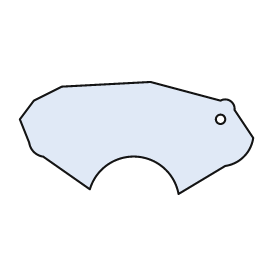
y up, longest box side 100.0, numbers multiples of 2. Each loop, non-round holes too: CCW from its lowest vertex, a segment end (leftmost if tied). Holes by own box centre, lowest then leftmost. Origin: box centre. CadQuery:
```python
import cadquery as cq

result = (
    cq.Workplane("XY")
    .moveTo(18.0, -24.0)
    .lineTo(38.0, -12.0)
    .threePointArc((46.0, -8.0), (50.0, 0.0))
    .lineTo(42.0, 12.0)
    .threePointArc((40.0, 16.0), (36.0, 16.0))
    .lineTo(6.0, 24.0)
    .lineTo(-32.0, 22.0)
    .lineTo(-44.0, 16.0)
    .lineTo(-50.0, 8.0)
    .lineTo(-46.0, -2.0)
    .threePointArc((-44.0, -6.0), (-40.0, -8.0))
    .lineTo(-20.0, -22.0)
    .threePointArc((0.0, -8.0), (18.0, -24.0))
    .close()
    .moveTo(36.0, 8.0)
    .circle(2.0)
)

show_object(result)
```